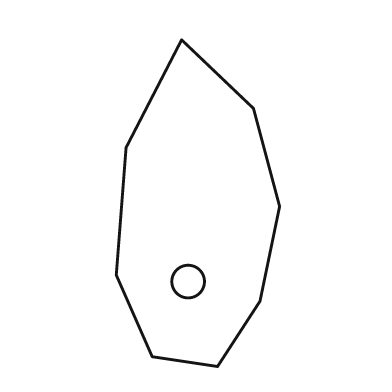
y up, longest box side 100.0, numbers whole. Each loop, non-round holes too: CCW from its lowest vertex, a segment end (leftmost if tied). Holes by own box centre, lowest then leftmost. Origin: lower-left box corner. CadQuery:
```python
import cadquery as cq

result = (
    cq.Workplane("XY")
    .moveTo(31.0, 0.0)
    .lineTo(44.0, 20.0)
    .lineTo(50.0, 49.0)
    .lineTo(42.0, 79.0)
    .lineTo(20.0, 100.0)
    .lineTo(3.0, 67.0)
    .lineTo(0.0, 28.0)
    .lineTo(11.0, 3.0)
    .close()
    .moveTo(22.0, 26.0)
    .circle(5.0)
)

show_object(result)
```